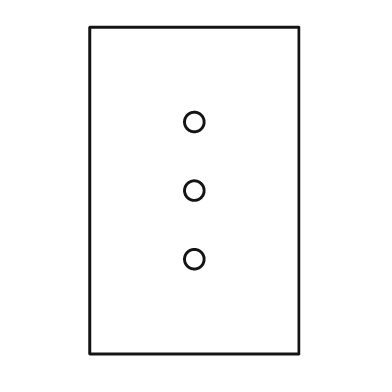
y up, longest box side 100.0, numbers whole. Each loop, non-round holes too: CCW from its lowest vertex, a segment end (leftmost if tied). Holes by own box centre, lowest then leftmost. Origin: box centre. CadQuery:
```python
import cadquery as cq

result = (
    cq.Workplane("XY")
    .moveTo(-32.0, -50.0)
    .lineTo(32.0, -50.0)
    .lineTo(32.0, 50.0)
    .lineTo(-32.0, 50.0)
    .close()
    .moveTo(0.0, -21.0)
    .circle(3.0)
    .moveTo(0.0, 0.0)
    .circle(3.0)
    .moveTo(0.0, 21.0)
    .circle(3.0)
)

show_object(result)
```